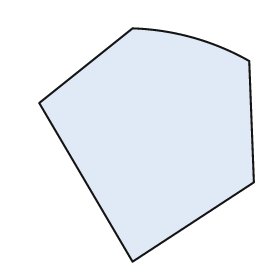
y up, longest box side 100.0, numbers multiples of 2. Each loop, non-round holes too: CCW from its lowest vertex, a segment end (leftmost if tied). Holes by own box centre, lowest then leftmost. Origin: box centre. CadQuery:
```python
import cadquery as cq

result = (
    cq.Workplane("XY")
    .moveTo(-6.0, -50.0)
    .lineTo(46.0, -16.0)
    .lineTo(44.0, 36.0)
    .threePointArc((20.0, 46.0), (-6.0, 50.0))
    .lineTo(-46.0, 18.0)
    .close()
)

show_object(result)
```